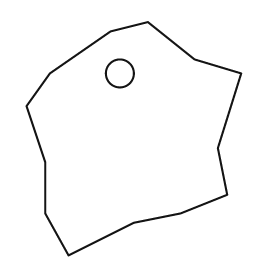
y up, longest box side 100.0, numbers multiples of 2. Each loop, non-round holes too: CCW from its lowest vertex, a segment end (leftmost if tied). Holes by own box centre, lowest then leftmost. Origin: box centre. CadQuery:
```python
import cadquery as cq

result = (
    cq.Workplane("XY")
    .moveTo(-28.0, -50.0)
    .lineTo(0.0, -36.0)
    .lineTo(20.0, -32.0)
    .lineTo(40.0, -24.0)
    .lineTo(36.0, -4.0)
    .lineTo(46.0, 28.0)
    .lineTo(26.0, 34.0)
    .lineTo(6.0, 50.0)
    .lineTo(-10.0, 46.0)
    .lineTo(-36.0, 28.0)
    .lineTo(-46.0, 14.0)
    .lineTo(-38.0, -10.0)
    .lineTo(-38.0, -32.0)
    .close()
    .moveTo(-6.0, 28.0)
    .circle(6.0)
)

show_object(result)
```